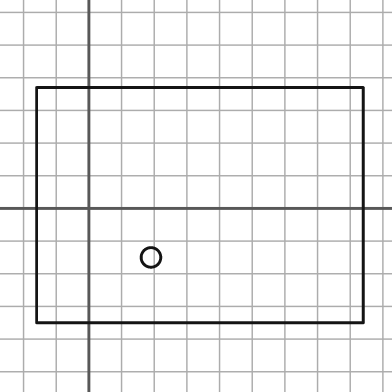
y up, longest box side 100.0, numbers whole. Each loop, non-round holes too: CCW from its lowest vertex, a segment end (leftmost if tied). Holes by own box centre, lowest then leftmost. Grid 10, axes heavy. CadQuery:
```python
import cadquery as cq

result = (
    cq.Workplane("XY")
    .moveTo(-16.0, -35.0)
    .lineTo(84.0, -35.0)
    .lineTo(84.0, 37.0)
    .lineTo(-16.0, 37.0)
    .close()
    .moveTo(19.0, -15.0)
    .circle(3.0)
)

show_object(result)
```